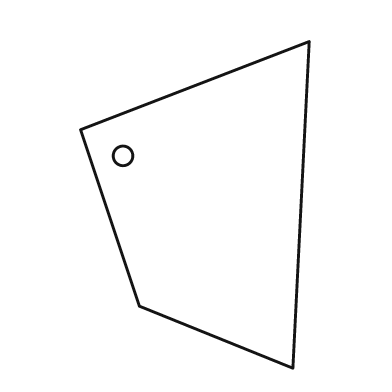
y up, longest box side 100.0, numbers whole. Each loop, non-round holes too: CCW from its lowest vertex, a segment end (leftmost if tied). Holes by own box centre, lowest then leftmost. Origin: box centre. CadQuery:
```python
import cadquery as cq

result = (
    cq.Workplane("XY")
    .moveTo(30.0, -50.0)
    .lineTo(35.0, 50.0)
    .lineTo(-35.0, 23.0)
    .lineTo(-17.0, -31.0)
    .close()
    .moveTo(-22.0, 15.0)
    .circle(3.0)
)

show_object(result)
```